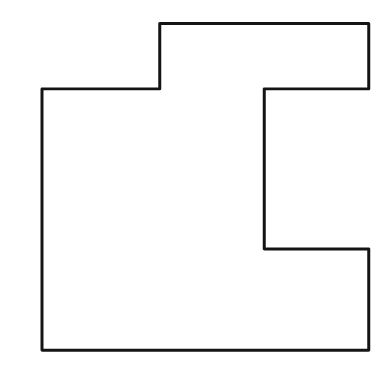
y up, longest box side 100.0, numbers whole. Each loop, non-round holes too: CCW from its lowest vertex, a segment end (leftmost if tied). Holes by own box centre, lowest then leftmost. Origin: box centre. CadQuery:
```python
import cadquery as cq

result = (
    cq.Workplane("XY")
    .moveTo(-50.0, -50.0)
    .lineTo(50.0, -50.0)
    .lineTo(50.0, -19.0)
    .lineTo(18.0, -19.0)
    .lineTo(18.0, 30.0)
    .lineTo(50.0, 30.0)
    .lineTo(50.0, 50.0)
    .lineTo(-14.0, 50.0)
    .lineTo(-14.0, 30.0)
    .lineTo(-50.0, 30.0)
    .close()
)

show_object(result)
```